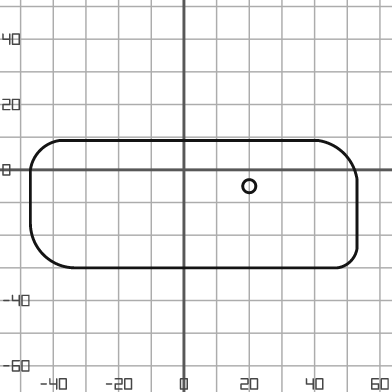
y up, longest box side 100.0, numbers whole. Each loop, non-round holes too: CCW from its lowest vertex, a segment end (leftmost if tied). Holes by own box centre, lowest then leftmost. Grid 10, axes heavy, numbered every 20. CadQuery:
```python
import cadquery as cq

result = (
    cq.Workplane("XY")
    .moveTo(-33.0, -30.0)
    .lineTo(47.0, -30.0)
    .threePointArc((51.0, -28.0), (53.0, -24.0))
    .lineTo(53.0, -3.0)
    .threePointArc((49.0, 5.0), (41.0, 9.0))
    .lineTo(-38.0, 9.0)
    .threePointArc((-44.0, 6.0), (-47.0, 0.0))
    .lineTo(-47.0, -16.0)
    .threePointArc((-43.0, -26.0), (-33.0, -30.0))
    .close()
    .moveTo(20.0, -5.0)
    .circle(2.0)
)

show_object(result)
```